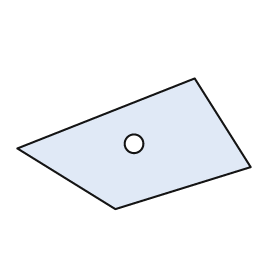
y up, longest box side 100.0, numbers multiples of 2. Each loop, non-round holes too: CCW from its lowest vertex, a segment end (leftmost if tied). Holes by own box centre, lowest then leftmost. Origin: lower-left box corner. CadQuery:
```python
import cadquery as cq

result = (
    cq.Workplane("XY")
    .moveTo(42.0, 0.0)
    .lineTo(100.0, 18.0)
    .lineTo(76.0, 56.0)
    .lineTo(0.0, 26.0)
    .close()
    .moveTo(50.0, 28.0)
    .circle(4.0)
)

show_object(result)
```